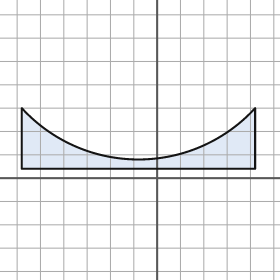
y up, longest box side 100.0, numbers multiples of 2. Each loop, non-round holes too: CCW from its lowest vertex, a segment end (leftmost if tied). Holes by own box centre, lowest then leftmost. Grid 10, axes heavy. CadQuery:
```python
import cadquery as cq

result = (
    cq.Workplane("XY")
    .moveTo(-58.0, 4.0)
    .lineTo(42.0, 4.0)
    .lineTo(42.0, 30.0)
    .threePointArc((-8.0, 8.0), (-58.0, 30.0))
    .close()
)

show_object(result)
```